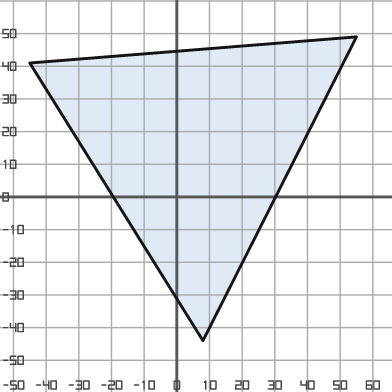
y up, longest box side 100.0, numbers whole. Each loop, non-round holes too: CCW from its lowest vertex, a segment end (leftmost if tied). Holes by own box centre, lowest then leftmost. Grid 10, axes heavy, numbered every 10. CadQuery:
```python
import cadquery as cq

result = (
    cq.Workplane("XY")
    .moveTo(8.0, -44.0)
    .lineTo(55.0, 49.0)
    .lineTo(-45.0, 41.0)
    .close()
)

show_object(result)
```